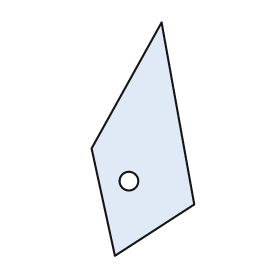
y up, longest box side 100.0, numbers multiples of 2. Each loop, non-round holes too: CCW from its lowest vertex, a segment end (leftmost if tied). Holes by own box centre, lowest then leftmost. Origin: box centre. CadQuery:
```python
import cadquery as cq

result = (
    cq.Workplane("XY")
    .moveTo(-12.0, -50.0)
    .lineTo(22.0, -28.0)
    .lineTo(8.0, 50.0)
    .lineTo(-22.0, -4.0)
    .close()
    .moveTo(-6.0, -18.0)
    .circle(4.0)
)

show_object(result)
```